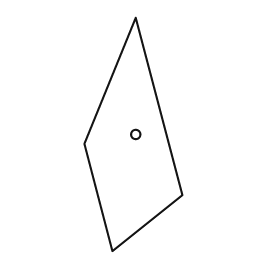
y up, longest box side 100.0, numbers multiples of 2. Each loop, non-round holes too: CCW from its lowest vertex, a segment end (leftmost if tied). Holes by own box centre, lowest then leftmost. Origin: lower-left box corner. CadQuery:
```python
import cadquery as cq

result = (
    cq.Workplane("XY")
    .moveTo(12.0, 0.0)
    .lineTo(42.0, 24.0)
    .lineTo(22.0, 100.0)
    .lineTo(0.0, 46.0)
    .close()
    .moveTo(22.0, 50.0)
    .circle(2.0)
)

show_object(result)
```